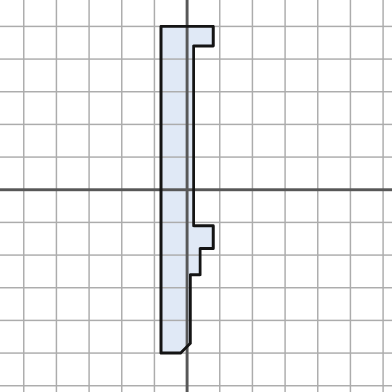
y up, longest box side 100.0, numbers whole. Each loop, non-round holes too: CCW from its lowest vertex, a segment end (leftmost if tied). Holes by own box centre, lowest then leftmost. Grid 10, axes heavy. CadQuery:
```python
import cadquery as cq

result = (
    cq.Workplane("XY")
    .moveTo(-8.0, -50.0)
    .lineTo(-2.0, -50.0)
    .lineTo(1.0, -47.0)
    .lineTo(1.0, -26.0)
    .lineTo(4.0, -26.0)
    .lineTo(4.0, -18.0)
    .lineTo(8.0, -18.0)
    .lineTo(8.0, -11.0)
    .lineTo(2.0, -11.0)
    .lineTo(2.0, 44.0)
    .lineTo(8.0, 44.0)
    .lineTo(8.0, 50.0)
    .lineTo(-8.0, 50.0)
    .close()
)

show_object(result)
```